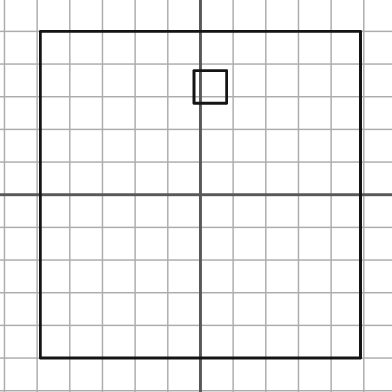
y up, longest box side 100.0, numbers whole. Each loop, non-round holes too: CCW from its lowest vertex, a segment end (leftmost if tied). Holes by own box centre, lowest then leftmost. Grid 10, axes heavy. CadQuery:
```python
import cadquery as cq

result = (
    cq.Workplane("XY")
    .moveTo(-49.0, -50.0)
    .lineTo(49.0, -50.0)
    .lineTo(49.0, 50.0)
    .lineTo(-49.0, 50.0)
    .close()
    .moveTo(-2.0, 28.0)
    .lineTo(8.0, 28.0)
    .lineTo(8.0, 38.0)
    .lineTo(-2.0, 38.0)
    .close()
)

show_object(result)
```